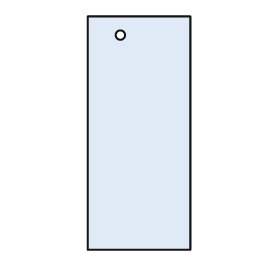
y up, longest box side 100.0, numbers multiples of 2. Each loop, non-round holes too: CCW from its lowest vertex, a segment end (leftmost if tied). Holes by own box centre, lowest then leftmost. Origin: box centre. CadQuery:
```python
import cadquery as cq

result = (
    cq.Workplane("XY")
    .moveTo(-22.0, -50.0)
    .lineTo(22.0, -50.0)
    .lineTo(22.0, 50.0)
    .lineTo(-22.0, 50.0)
    .close()
    .moveTo(-8.0, 42.0)
    .circle(2.0)
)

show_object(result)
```